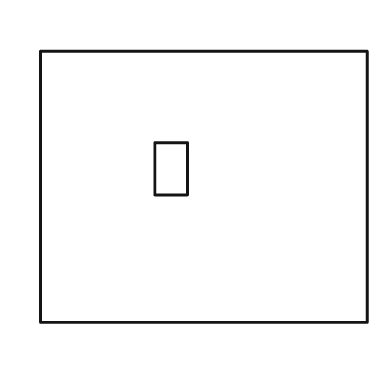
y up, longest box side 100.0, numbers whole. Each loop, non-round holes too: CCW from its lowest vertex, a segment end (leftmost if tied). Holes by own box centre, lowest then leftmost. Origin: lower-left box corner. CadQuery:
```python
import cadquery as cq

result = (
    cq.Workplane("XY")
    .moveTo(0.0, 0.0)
    .lineTo(100.0, 0.0)
    .lineTo(100.0, 83.0)
    .lineTo(0.0, 83.0)
    .close()
    .moveTo(35.0, 39.0)
    .lineTo(45.0, 39.0)
    .lineTo(45.0, 55.0)
    .lineTo(35.0, 55.0)
    .close()
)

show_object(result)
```